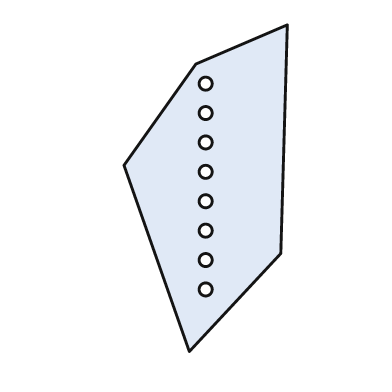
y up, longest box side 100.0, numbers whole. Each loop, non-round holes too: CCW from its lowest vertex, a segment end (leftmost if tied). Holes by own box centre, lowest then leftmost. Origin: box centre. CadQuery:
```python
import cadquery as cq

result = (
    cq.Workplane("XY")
    .moveTo(-5.0, -50.0)
    .lineTo(23.0, -20.0)
    .lineTo(25.0, 50.0)
    .lineTo(-3.0, 38.0)
    .lineTo(-25.0, 7.0)
    .close()
    .moveTo(0.0, -31.0)
    .circle(2.0)
    .moveTo(0.0, -22.0)
    .circle(2.0)
    .moveTo(0.0, -13.0)
    .circle(2.0)
    .moveTo(0.0, -4.0)
    .circle(2.0)
    .moveTo(0.0, 5.0)
    .circle(2.0)
    .moveTo(0.0, 14.0)
    .circle(2.0)
    .moveTo(0.0, 23.0)
    .circle(2.0)
    .moveTo(0.0, 32.0)
    .circle(2.0)
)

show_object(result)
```